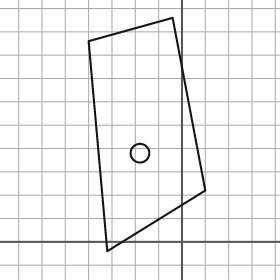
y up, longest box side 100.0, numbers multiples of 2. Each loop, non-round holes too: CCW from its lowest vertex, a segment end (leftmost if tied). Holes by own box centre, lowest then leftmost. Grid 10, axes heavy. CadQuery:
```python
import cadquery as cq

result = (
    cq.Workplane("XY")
    .moveTo(-32.0, -4.0)
    .lineTo(10.0, 22.0)
    .lineTo(-4.0, 96.0)
    .lineTo(-40.0, 86.0)
    .close()
    .moveTo(-18.0, 38.0)
    .circle(4.0)
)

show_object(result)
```